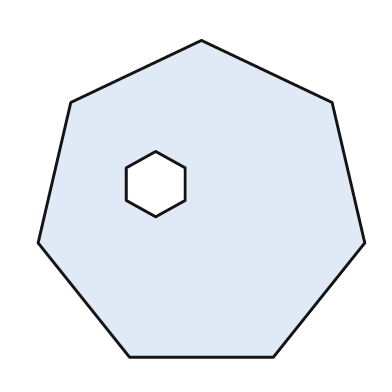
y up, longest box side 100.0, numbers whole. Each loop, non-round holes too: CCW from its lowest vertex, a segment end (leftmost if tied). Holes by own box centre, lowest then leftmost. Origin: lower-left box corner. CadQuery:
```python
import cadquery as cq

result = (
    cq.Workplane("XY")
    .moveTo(28.0, 0.0)
    .lineTo(72.0, 0.0)
    .lineTo(100.0, 35.0)
    .lineTo(90.0, 78.0)
    .lineTo(50.0, 97.0)
    .lineTo(10.0, 78.0)
    .lineTo(0.0, 35.0)
    .close()
    .moveTo(36.0, 43.0)
    .lineTo(45.0, 48.0)
    .lineTo(45.0, 58.0)
    .lineTo(36.0, 63.0)
    .lineTo(27.0, 58.0)
    .lineTo(27.0, 48.0)
    .close()
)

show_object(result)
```